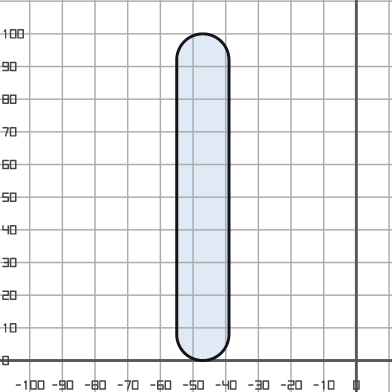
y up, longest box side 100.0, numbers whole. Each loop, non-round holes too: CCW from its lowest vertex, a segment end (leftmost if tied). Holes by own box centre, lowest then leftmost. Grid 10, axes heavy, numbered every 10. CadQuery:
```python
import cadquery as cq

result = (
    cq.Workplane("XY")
    .moveTo(-55.0, 8.0)
    .threePointArc((-47.0, 0.0), (-39.0, 8.0))
    .lineTo(-39.0, 92.0)
    .threePointArc((-47.0, 100.0), (-55.0, 92.0))
    .close()
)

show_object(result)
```